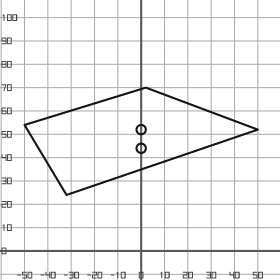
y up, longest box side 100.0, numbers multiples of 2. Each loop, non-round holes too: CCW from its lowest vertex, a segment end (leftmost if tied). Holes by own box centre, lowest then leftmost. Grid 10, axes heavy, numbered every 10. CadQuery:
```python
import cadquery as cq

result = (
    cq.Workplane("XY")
    .moveTo(-32.0, 24.0)
    .lineTo(50.0, 52.0)
    .lineTo(2.0, 70.0)
    .lineTo(-50.0, 54.0)
    .close()
    .moveTo(0.0, 44.0)
    .circle(2.0)
    .moveTo(0.0, 52.0)
    .circle(2.0)
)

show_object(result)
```